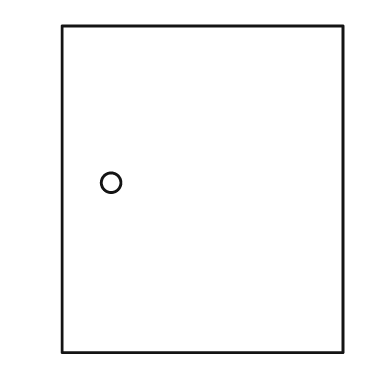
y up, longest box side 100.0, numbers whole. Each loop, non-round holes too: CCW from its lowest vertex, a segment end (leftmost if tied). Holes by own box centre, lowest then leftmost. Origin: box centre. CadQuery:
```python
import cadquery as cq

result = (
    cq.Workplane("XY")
    .moveTo(-43.0, -50.0)
    .lineTo(43.0, -50.0)
    .lineTo(43.0, 50.0)
    .lineTo(-43.0, 50.0)
    .close()
    .moveTo(-28.0, 2.0)
    .circle(3.0)
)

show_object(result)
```